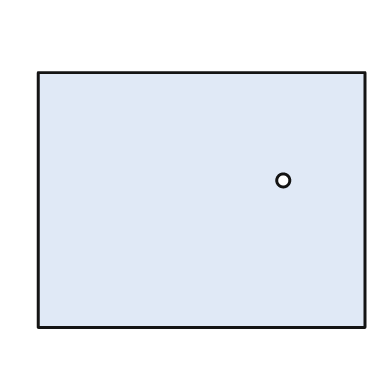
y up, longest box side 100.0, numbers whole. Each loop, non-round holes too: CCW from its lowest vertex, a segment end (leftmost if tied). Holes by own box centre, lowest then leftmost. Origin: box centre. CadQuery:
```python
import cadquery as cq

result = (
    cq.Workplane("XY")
    .moveTo(-50.0, -39.0)
    .lineTo(50.0, -39.0)
    .lineTo(50.0, 39.0)
    .lineTo(-50.0, 39.0)
    .close()
    .moveTo(25.0, 6.0)
    .circle(2.0)
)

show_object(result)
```